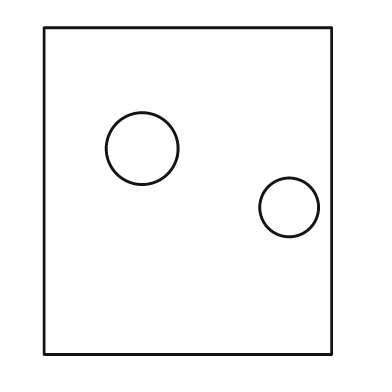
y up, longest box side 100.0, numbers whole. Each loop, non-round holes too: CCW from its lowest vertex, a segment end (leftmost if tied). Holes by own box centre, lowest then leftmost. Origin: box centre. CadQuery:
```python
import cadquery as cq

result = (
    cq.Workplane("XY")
    .moveTo(-44.0, -50.0)
    .lineTo(44.0, -50.0)
    .lineTo(44.0, 50.0)
    .lineTo(-44.0, 50.0)
    .close()
    .moveTo(31.0, -5.0)
    .circle(9.0)
    .moveTo(-14.0, 13.0)
    .circle(11.0)
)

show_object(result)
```